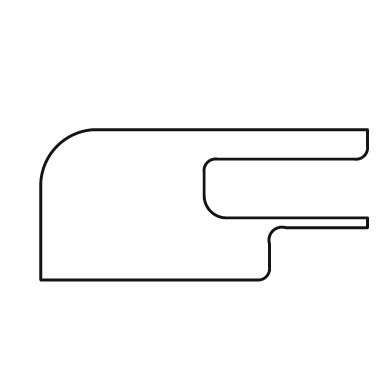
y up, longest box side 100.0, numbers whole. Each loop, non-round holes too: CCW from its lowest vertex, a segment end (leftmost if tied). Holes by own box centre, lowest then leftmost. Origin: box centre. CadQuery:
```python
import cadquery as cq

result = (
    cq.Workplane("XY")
    .moveTo(-50.0, -23.0)
    .lineTo(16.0, -23.0)
    .threePointArc((19.0, -22.0), (20.0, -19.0))
    .lineTo(20.0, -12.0)
    .threePointArc((21.0, -8.0), (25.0, -7.0))
    .lineTo(50.0, -7.0)
    .lineTo(50.0, -4.0)
    .lineTo(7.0, -4.0)
    .threePointArc((2.0, -2.0), (0.0, 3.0))
    .lineTo(0.0, 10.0)
    .threePointArc((1.0, 13.0), (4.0, 14.0))
    .lineTo(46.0, 14.0)
    .threePointArc((49.0, 15.0), (50.0, 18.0))
    .lineTo(50.0, 23.0)
    .lineTo(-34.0, 23.0)
    .threePointArc((-45.0, 18.0), (-50.0, 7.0))
    .close()
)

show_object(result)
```